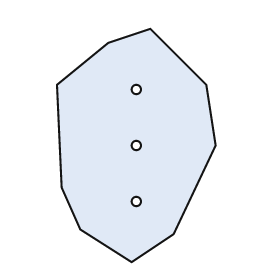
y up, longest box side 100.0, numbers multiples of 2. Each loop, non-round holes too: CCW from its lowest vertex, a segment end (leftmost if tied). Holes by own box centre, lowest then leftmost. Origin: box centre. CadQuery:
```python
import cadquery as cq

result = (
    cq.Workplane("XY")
    .moveTo(-2.0, -50.0)
    .lineTo(16.0, -38.0)
    .lineTo(34.0, 0.0)
    .lineTo(30.0, 26.0)
    .lineTo(6.0, 50.0)
    .lineTo(-12.0, 44.0)
    .lineTo(-34.0, 26.0)
    .lineTo(-32.0, -18.0)
    .lineTo(-24.0, -36.0)
    .close()
    .moveTo(0.0, -24.0)
    .circle(2.0)
    .moveTo(0.0, 0.0)
    .circle(2.0)
    .moveTo(0.0, 24.0)
    .circle(2.0)
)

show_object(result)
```